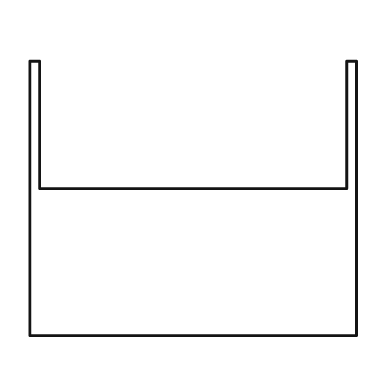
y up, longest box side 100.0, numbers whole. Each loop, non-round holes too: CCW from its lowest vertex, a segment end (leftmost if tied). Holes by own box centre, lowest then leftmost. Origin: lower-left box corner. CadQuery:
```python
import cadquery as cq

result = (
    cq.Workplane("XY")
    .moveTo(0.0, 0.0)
    .lineTo(100.0, 0.0)
    .lineTo(100.0, 84.0)
    .lineTo(97.0, 84.0)
    .lineTo(97.0, 45.0)
    .lineTo(3.0, 45.0)
    .lineTo(3.0, 84.0)
    .lineTo(0.0, 84.0)
    .close()
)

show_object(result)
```